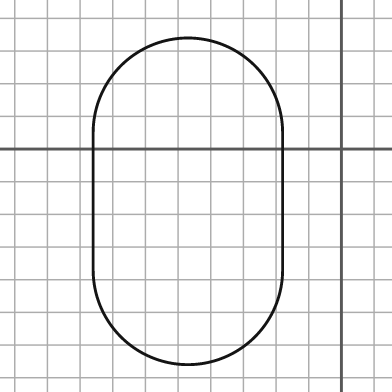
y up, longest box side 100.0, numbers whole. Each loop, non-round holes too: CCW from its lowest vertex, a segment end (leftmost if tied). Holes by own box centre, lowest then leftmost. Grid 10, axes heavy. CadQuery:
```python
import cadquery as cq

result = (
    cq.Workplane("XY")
    .moveTo(-76.0, -37.0)
    .threePointArc((-47.0, -66.0), (-18.0, -37.0))
    .lineTo(-18.0, 5.0)
    .threePointArc((-47.0, 34.0), (-76.0, 5.0))
    .close()
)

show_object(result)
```